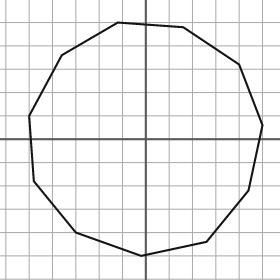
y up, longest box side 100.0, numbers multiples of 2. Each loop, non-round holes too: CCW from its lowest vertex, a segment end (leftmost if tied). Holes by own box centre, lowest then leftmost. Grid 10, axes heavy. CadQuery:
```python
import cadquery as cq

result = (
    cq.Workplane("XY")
    .moveTo(-2.0, -50.0)
    .lineTo(26.0, -44.0)
    .lineTo(44.0, -22.0)
    .lineTo(50.0, 6.0)
    .lineTo(40.0, 32.0)
    .lineTo(16.0, 48.0)
    .lineTo(-12.0, 50.0)
    .lineTo(-36.0, 36.0)
    .lineTo(-50.0, 10.0)
    .lineTo(-48.0, -18.0)
    .lineTo(-30.0, -40.0)
    .close()
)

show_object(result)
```